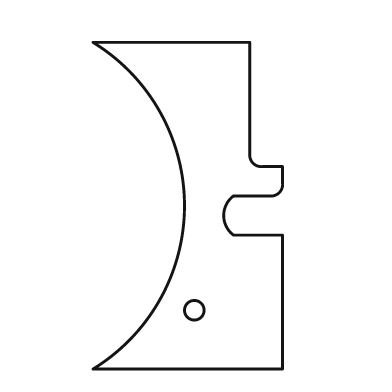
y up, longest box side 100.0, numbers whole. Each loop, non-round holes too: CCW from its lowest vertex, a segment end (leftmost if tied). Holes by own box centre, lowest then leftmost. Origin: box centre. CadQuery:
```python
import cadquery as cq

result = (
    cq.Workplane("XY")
    .moveTo(-29.0, -50.0)
    .lineTo(29.0, -50.0)
    .lineTo(29.0, -9.0)
    .lineTo(14.0, -9.0)
    .threePointArc((11.0, -3.0), (14.0, 3.0))
    .lineTo(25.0, 3.0)
    .threePointArc((28.0, 4.0), (29.0, 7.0))
    .lineTo(29.0, 12.0)
    .lineTo(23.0, 12.0)
    .threePointArc((20.0, 13.0), (19.0, 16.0))
    .lineTo(19.0, 50.0)
    .lineTo(-29.0, 50.0)
    .threePointArc((-1.0, 0.0), (-29.0, -50.0))
    .close()
    .moveTo(2.0, -32.0)
    .circle(3.0)
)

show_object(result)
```